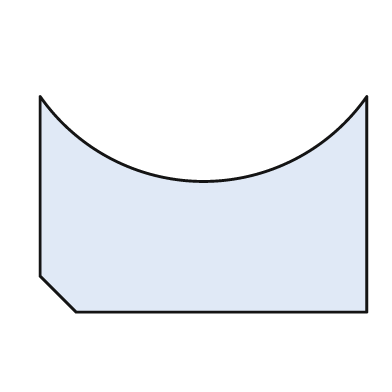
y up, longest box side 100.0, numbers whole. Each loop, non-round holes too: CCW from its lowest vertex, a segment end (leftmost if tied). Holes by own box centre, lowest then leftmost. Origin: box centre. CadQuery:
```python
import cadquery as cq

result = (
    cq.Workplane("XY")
    .moveTo(-39.0, -33.0)
    .lineTo(50.0, -33.0)
    .lineTo(50.0, 33.0)
    .threePointArc((0.0, 7.0), (-50.0, 33.0))
    .lineTo(-50.0, -22.0)
    .close()
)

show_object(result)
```